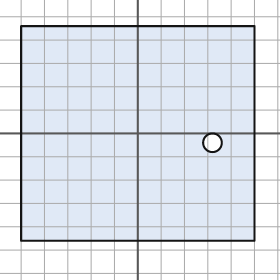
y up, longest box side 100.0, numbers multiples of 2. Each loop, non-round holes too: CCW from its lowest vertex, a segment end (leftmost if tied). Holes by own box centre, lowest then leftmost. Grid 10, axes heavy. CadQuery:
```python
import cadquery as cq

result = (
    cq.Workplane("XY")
    .moveTo(-50.0, -46.0)
    .lineTo(50.0, -46.0)
    .lineTo(50.0, 46.0)
    .lineTo(-50.0, 46.0)
    .close()
    .moveTo(32.0, -4.0)
    .circle(4.0)
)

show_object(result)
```